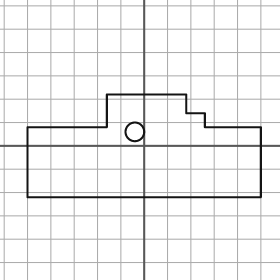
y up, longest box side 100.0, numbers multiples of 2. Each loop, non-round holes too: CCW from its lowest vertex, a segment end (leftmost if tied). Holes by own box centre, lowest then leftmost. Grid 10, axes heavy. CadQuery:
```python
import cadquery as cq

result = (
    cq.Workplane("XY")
    .moveTo(-50.0, -22.0)
    .lineTo(50.0, -22.0)
    .lineTo(50.0, 8.0)
    .lineTo(26.0, 8.0)
    .lineTo(26.0, 14.0)
    .lineTo(18.0, 14.0)
    .lineTo(18.0, 22.0)
    .lineTo(-16.0, 22.0)
    .lineTo(-16.0, 8.0)
    .lineTo(-50.0, 8.0)
    .close()
    .moveTo(-4.0, 6.0)
    .circle(4.0)
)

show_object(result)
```